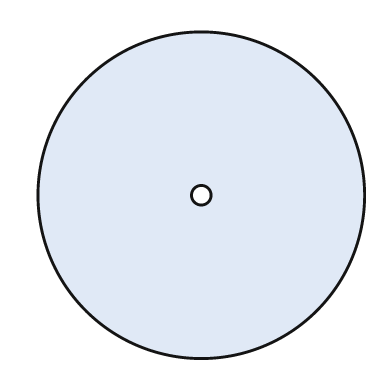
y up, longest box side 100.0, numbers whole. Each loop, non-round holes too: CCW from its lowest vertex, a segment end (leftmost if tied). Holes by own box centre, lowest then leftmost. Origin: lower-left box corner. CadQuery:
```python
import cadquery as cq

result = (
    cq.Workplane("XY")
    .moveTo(50.0, 50.0)
    .circle(50.0)
    .moveTo(50.0, 50.0)
    .circle(3.0)
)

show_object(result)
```